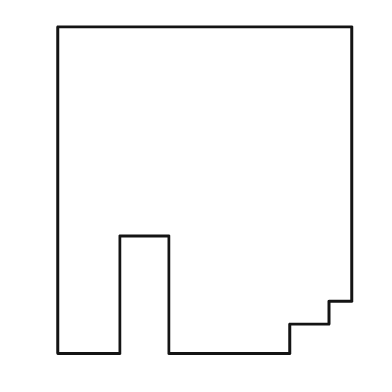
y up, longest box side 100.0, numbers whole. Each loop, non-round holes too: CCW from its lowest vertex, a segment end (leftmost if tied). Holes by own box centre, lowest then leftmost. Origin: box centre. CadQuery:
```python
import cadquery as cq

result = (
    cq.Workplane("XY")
    .moveTo(-45.0, -50.0)
    .lineTo(-26.0, -50.0)
    .lineTo(-26.0, -14.0)
    .lineTo(-11.0, -14.0)
    .lineTo(-11.0, -50.0)
    .lineTo(26.0, -50.0)
    .lineTo(26.0, -41.0)
    .lineTo(38.0, -41.0)
    .lineTo(38.0, -34.0)
    .lineTo(45.0, -34.0)
    .lineTo(45.0, 50.0)
    .lineTo(-45.0, 50.0)
    .close()
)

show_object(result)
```